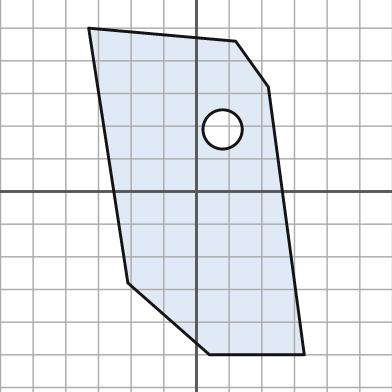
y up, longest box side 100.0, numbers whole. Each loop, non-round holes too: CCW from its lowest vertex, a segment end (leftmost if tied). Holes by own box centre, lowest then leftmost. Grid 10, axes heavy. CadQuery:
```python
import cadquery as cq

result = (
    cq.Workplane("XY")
    .moveTo(4.0, -50.0)
    .lineTo(33.0, -50.0)
    .lineTo(22.0, 32.0)
    .lineTo(12.0, 46.0)
    .lineTo(-33.0, 50.0)
    .lineTo(-21.0, -28.0)
    .close()
    .moveTo(8.0, 19.0)
    .circle(6.0)
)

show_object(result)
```